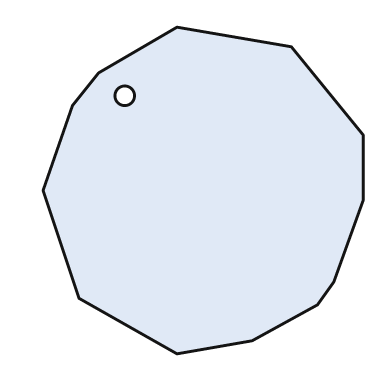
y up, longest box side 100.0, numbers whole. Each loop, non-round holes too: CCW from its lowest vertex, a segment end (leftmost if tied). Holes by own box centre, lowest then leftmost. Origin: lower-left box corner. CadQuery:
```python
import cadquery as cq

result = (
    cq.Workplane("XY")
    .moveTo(41.0, 0.0)
    .lineTo(64.0, 4.0)
    .lineTo(84.0, 15.0)
    .lineTo(89.0, 22.0)
    .lineTo(98.0, 47.0)
    .lineTo(98.0, 67.0)
    .lineTo(76.0, 94.0)
    .lineTo(41.0, 100.0)
    .lineTo(17.0, 86.0)
    .lineTo(9.0, 76.0)
    .lineTo(0.0, 50.0)
    .lineTo(11.0, 17.0)
    .close()
    .moveTo(25.0, 79.0)
    .circle(3.0)
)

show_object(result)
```